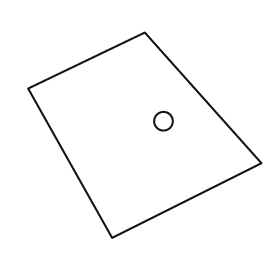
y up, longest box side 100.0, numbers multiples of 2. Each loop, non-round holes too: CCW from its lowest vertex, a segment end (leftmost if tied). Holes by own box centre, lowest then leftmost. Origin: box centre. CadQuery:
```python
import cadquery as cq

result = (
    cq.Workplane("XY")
    .moveTo(-14.0, -44.0)
    .lineTo(50.0, -12.0)
    .lineTo(0.0, 44.0)
    .lineTo(-50.0, 20.0)
    .close()
    .moveTo(8.0, 6.0)
    .circle(4.0)
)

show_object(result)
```